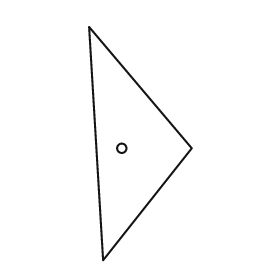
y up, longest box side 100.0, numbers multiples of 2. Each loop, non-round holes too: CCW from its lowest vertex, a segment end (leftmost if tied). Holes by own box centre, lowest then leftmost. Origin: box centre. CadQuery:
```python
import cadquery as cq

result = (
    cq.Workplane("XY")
    .moveTo(-16.0, -50.0)
    .lineTo(22.0, -2.0)
    .lineTo(-22.0, 50.0)
    .close()
    .moveTo(-8.0, -2.0)
    .circle(2.0)
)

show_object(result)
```